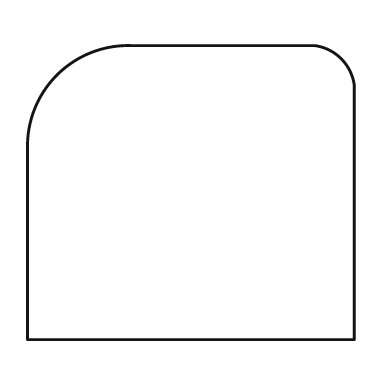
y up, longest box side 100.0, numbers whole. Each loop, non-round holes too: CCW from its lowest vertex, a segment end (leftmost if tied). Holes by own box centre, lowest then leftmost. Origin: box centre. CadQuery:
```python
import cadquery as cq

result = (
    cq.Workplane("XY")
    .moveTo(-50.0, -45.0)
    .lineTo(50.0, -45.0)
    .lineTo(50.0, 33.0)
    .threePointArc((46.0, 41.0), (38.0, 45.0))
    .lineTo(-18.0, 45.0)
    .threePointArc((-41.0, 36.0), (-50.0, 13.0))
    .close()
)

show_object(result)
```